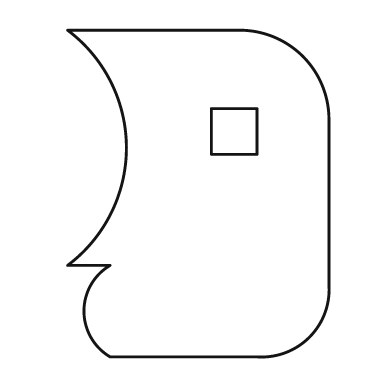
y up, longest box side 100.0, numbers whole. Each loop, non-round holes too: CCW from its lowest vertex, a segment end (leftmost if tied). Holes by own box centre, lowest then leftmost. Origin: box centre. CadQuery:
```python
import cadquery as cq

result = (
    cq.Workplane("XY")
    .moveTo(-27.0, -50.0)
    .lineTo(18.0, -50.0)
    .threePointArc((34.0, -44.0), (40.0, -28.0))
    .lineTo(40.0, 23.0)
    .threePointArc((32.0, 42.0), (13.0, 50.0))
    .lineTo(-40.0, 50.0)
    .threePointArc((-22.0, 14.0), (-40.0, -22.0))
    .lineTo(-27.0, -22.0)
    .threePointArc((-35.0, -36.0), (-27.0, -50.0))
    .close()
    .moveTo(4.0, 12.0)
    .lineTo(18.0, 12.0)
    .lineTo(18.0, 26.0)
    .lineTo(4.0, 26.0)
    .close()
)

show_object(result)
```